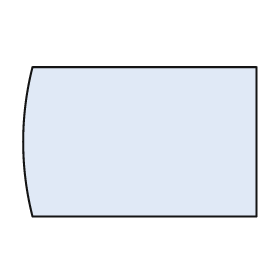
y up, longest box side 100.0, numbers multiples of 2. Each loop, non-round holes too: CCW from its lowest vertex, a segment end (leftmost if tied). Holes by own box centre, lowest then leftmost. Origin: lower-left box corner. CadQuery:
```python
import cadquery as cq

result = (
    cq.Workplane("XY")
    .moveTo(4.0, 0.0)
    .lineTo(100.0, 0.0)
    .lineTo(100.0, 64.0)
    .lineTo(4.0, 64.0)
    .threePointArc((0.0, 32.0), (4.0, 0.0))
    .close()
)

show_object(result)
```